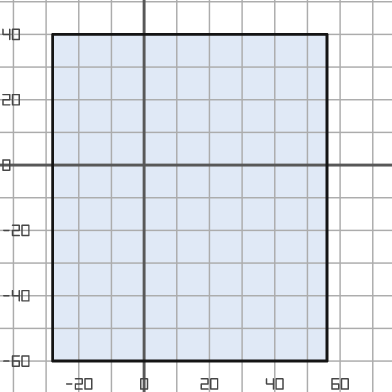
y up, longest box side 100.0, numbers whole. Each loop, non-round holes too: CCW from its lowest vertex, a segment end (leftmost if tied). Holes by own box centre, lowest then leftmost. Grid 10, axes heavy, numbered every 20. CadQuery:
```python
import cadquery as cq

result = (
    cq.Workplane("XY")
    .moveTo(-28.0, -60.0)
    .lineTo(56.0, -60.0)
    .lineTo(56.0, 40.0)
    .lineTo(-28.0, 40.0)
    .close()
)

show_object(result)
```